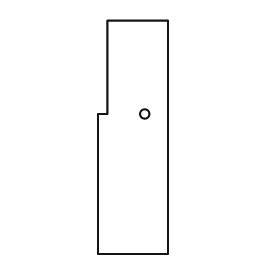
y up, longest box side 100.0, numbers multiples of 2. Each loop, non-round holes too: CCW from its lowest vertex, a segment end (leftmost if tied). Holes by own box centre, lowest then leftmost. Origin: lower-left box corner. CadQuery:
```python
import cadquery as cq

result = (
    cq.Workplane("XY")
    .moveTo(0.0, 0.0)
    .lineTo(30.0, 0.0)
    .lineTo(30.0, 100.0)
    .lineTo(4.0, 100.0)
    .lineTo(4.0, 60.0)
    .lineTo(0.0, 60.0)
    .close()
    .moveTo(20.0, 60.0)
    .circle(2.0)
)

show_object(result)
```